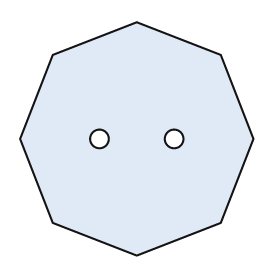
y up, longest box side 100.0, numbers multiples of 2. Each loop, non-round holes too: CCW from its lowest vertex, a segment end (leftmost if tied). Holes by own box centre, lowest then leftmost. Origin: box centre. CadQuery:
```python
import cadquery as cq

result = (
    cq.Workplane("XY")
    .moveTo(0.0, -50.0)
    .lineTo(36.0, -36.0)
    .lineTo(50.0, 0.0)
    .lineTo(36.0, 36.0)
    .lineTo(0.0, 50.0)
    .lineTo(-36.0, 36.0)
    .lineTo(-50.0, 0.0)
    .lineTo(-36.0, -36.0)
    .close()
    .moveTo(-16.0, 0.0)
    .circle(4.0)
    .moveTo(16.0, 0.0)
    .circle(4.0)
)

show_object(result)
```